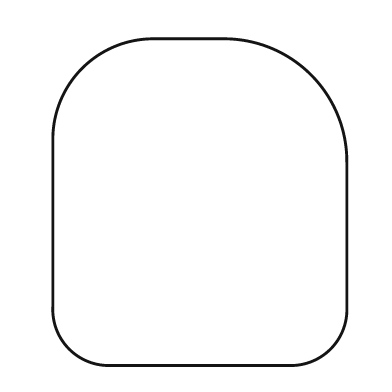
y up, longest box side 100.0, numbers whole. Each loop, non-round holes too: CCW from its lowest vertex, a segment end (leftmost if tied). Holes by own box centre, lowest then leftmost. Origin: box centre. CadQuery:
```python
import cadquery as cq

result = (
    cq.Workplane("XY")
    .moveTo(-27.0, -50.0)
    .lineTo(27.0, -50.0)
    .threePointArc((40.0, -45.0), (45.0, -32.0))
    .lineTo(45.0, 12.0)
    .threePointArc((34.0, 39.0), (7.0, 50.0))
    .lineTo(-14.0, 50.0)
    .threePointArc((-36.0, 41.0), (-45.0, 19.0))
    .lineTo(-45.0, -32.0)
    .threePointArc((-40.0, -45.0), (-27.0, -50.0))
    .close()
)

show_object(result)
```